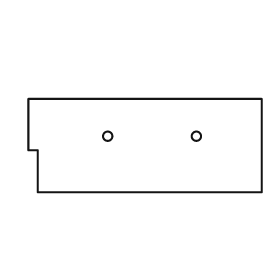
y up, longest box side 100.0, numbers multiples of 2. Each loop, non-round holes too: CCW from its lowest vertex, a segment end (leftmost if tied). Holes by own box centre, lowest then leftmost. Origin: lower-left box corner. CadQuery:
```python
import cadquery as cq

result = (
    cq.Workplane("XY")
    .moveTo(4.0, 0.0)
    .lineTo(100.0, 0.0)
    .lineTo(100.0, 40.0)
    .lineTo(0.0, 40.0)
    .lineTo(0.0, 18.0)
    .lineTo(4.0, 18.0)
    .close()
    .moveTo(34.0, 24.0)
    .circle(2.0)
    .moveTo(72.0, 24.0)
    .circle(2.0)
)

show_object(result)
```